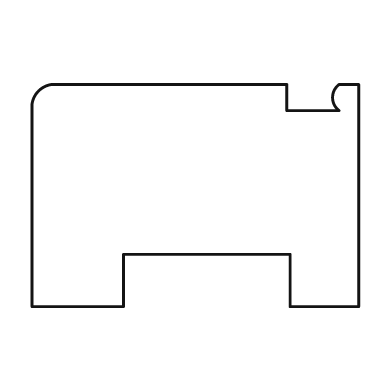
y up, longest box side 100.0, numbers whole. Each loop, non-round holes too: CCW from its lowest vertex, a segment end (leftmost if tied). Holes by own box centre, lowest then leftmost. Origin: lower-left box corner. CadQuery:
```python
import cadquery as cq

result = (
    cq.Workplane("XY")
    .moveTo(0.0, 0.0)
    .lineTo(28.0, 0.0)
    .lineTo(28.0, 16.0)
    .lineTo(79.0, 16.0)
    .lineTo(79.0, 0.0)
    .lineTo(100.0, 0.0)
    .lineTo(100.0, 68.0)
    .lineTo(94.0, 68.0)
    .threePointArc((92.0, 64.0), (94.0, 60.0))
    .lineTo(78.0, 60.0)
    .lineTo(78.0, 68.0)
    .lineTo(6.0, 68.0)
    .threePointArc((2.0, 66.0), (0.0, 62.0))
    .close()
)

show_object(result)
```